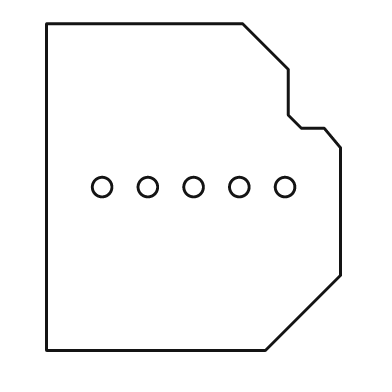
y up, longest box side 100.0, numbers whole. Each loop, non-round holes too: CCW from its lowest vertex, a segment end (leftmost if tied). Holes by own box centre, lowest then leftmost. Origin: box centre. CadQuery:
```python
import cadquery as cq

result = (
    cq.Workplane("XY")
    .moveTo(-45.0, -50.0)
    .lineTo(22.0, -50.0)
    .lineTo(45.0, -27.0)
    .lineTo(45.0, 12.0)
    .lineTo(40.0, 18.0)
    .lineTo(33.0, 18.0)
    .lineTo(29.0, 22.0)
    .lineTo(29.0, 36.0)
    .lineTo(15.0, 50.0)
    .lineTo(-45.0, 50.0)
    .close()
    .moveTo(-28.0, 0.0)
    .circle(3.0)
    .moveTo(-14.0, 0.0)
    .circle(3.0)
    .moveTo(0.0, 0.0)
    .circle(3.0)
    .moveTo(14.0, 0.0)
    .circle(3.0)
    .moveTo(28.0, 0.0)
    .circle(3.0)
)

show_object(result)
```